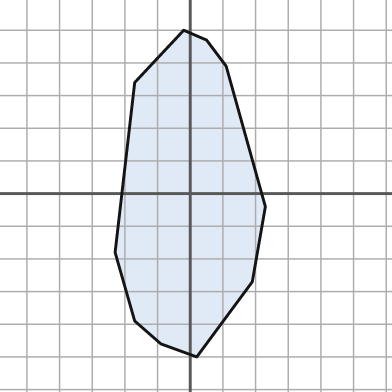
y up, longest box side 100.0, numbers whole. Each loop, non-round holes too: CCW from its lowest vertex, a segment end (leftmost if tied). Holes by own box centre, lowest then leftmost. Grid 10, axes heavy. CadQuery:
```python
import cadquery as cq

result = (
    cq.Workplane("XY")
    .moveTo(2.0, -50.0)
    .lineTo(19.0, -27.0)
    .lineTo(23.0, -4.0)
    .lineTo(11.0, 39.0)
    .lineTo(5.0, 47.0)
    .lineTo(-2.0, 50.0)
    .lineTo(-17.0, 34.0)
    .lineTo(-23.0, -18.0)
    .lineTo(-17.0, -39.0)
    .lineTo(-9.0, -46.0)
    .close()
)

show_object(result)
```